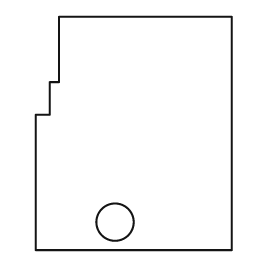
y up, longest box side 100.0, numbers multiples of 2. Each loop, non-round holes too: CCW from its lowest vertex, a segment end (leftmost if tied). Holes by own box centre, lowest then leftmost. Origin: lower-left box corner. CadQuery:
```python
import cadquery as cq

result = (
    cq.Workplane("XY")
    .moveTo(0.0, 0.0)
    .lineTo(84.0, 0.0)
    .lineTo(84.0, 100.0)
    .lineTo(10.0, 100.0)
    .lineTo(10.0, 72.0)
    .lineTo(6.0, 72.0)
    .lineTo(6.0, 58.0)
    .lineTo(0.0, 58.0)
    .close()
    .moveTo(34.0, 12.0)
    .circle(8.0)
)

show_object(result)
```